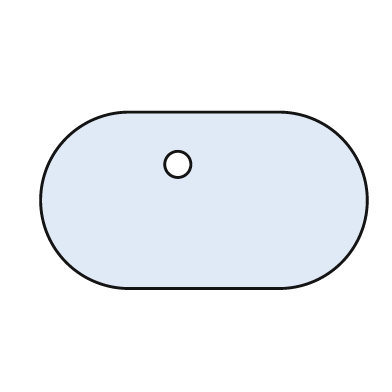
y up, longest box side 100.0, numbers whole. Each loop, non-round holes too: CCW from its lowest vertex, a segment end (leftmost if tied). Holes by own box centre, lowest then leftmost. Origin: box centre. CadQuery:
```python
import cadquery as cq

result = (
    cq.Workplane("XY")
    .moveTo(-23.0, -27.0)
    .lineTo(23.0, -27.0)
    .threePointArc((50.0, 0.0), (23.0, 27.0))
    .lineTo(-23.0, 27.0)
    .threePointArc((-50.0, 0.0), (-23.0, -27.0))
    .close()
    .moveTo(-8.0, 11.0)
    .circle(4.0)
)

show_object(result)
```